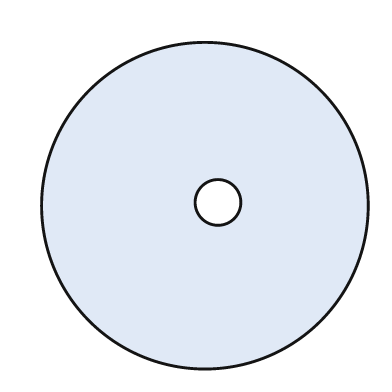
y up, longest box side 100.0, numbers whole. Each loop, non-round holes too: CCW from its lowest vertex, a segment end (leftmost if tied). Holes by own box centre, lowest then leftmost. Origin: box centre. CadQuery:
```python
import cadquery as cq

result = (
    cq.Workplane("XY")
    .moveTo(0.0, 0.0)
    .circle(50.0)
    .moveTo(4.0, 1.0)
    .circle(7.0)
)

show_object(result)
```